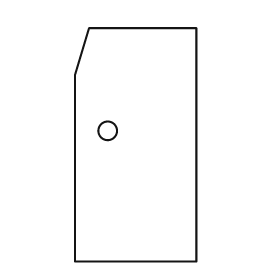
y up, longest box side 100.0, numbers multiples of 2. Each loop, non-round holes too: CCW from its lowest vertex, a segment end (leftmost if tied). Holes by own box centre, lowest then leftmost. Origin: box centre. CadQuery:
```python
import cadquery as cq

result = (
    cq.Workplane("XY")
    .moveTo(-26.0, -50.0)
    .lineTo(26.0, -50.0)
    .lineTo(26.0, 50.0)
    .lineTo(-20.0, 50.0)
    .lineTo(-26.0, 30.0)
    .close()
    .moveTo(-12.0, 6.0)
    .circle(4.0)
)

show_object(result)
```